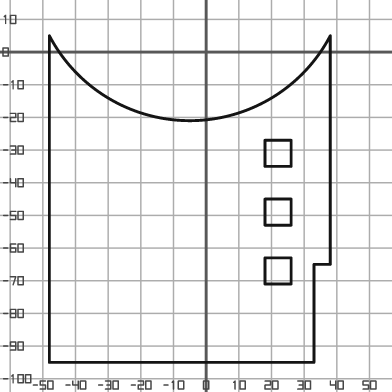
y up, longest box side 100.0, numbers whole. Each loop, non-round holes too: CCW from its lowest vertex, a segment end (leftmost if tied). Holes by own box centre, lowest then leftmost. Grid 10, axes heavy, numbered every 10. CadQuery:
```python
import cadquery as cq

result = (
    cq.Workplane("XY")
    .moveTo(-48.0, -95.0)
    .lineTo(33.0, -95.0)
    .lineTo(33.0, -65.0)
    .lineTo(38.0, -65.0)
    .lineTo(38.0, 5.0)
    .threePointArc((-5.0, -21.0), (-48.0, 5.0))
    .close()
    .moveTo(18.0, -71.0)
    .lineTo(26.0, -71.0)
    .lineTo(26.0, -63.0)
    .lineTo(18.0, -63.0)
    .close()
    .moveTo(18.0, -53.0)
    .lineTo(26.0, -53.0)
    .lineTo(26.0, -45.0)
    .lineTo(18.0, -45.0)
    .close()
    .moveTo(18.0, -35.0)
    .lineTo(26.0, -35.0)
    .lineTo(26.0, -27.0)
    .lineTo(18.0, -27.0)
    .close()
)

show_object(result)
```